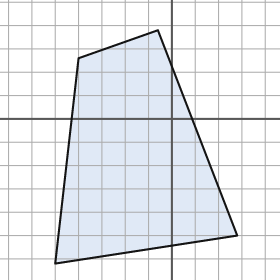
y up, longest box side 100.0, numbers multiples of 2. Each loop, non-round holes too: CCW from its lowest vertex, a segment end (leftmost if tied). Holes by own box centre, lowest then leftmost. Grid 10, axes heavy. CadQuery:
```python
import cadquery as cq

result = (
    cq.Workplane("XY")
    .moveTo(-50.0, -62.0)
    .lineTo(28.0, -50.0)
    .lineTo(-6.0, 38.0)
    .lineTo(-40.0, 26.0)
    .close()
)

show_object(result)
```